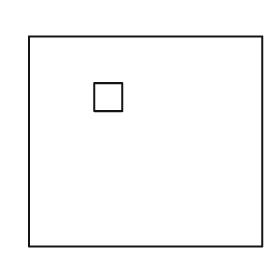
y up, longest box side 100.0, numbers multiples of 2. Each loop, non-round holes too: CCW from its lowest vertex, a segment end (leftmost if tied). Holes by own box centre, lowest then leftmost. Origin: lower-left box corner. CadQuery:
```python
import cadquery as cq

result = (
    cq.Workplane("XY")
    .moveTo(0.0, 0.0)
    .lineTo(100.0, 0.0)
    .lineTo(100.0, 90.0)
    .lineTo(0.0, 90.0)
    .close()
    .moveTo(28.0, 58.0)
    .lineTo(40.0, 58.0)
    .lineTo(40.0, 70.0)
    .lineTo(28.0, 70.0)
    .close()
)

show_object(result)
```